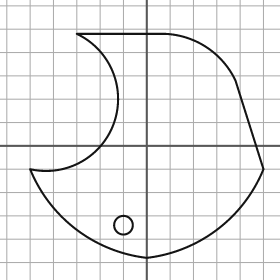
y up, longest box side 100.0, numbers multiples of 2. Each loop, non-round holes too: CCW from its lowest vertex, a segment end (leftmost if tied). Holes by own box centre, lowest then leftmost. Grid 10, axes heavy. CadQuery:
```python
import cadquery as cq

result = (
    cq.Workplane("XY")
    .moveTo(0.0, -48.0)
    .threePointArc((30.0, -36.0), (50.0, -10.0))
    .lineTo(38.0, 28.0)
    .threePointArc((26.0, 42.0), (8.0, 48.0))
    .lineTo(-30.0, 48.0)
    .threePointArc((-14.0, 10.0), (-50.0, -10.0))
    .threePointArc((-30.0, -36.0), (0.0, -48.0))
    .close()
    .moveTo(-10.0, -34.0)
    .circle(4.0)
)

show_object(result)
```